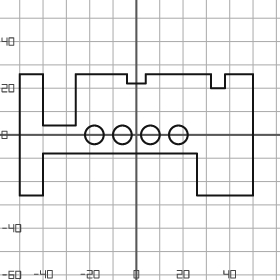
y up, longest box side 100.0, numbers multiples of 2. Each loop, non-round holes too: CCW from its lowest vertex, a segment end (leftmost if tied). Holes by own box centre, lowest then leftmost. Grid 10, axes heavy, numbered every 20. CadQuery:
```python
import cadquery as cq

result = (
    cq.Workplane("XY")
    .moveTo(-50.0, -26.0)
    .lineTo(-40.0, -26.0)
    .lineTo(-40.0, -8.0)
    .lineTo(26.0, -8.0)
    .lineTo(26.0, -26.0)
    .lineTo(50.0, -26.0)
    .lineTo(50.0, 26.0)
    .lineTo(38.0, 26.0)
    .lineTo(38.0, 20.0)
    .lineTo(32.0, 20.0)
    .lineTo(32.0, 26.0)
    .lineTo(4.0, 26.0)
    .lineTo(4.0, 22.0)
    .lineTo(-4.0, 22.0)
    .lineTo(-4.0, 26.0)
    .lineTo(-26.0, 26.0)
    .lineTo(-26.0, 4.0)
    .lineTo(-40.0, 4.0)
    .lineTo(-40.0, 26.0)
    .lineTo(-50.0, 26.0)
    .close()
    .moveTo(-18.0, 0.0)
    .circle(4.0)
    .moveTo(-6.0, 0.0)
    .circle(4.0)
    .moveTo(6.0, 0.0)
    .circle(4.0)
    .moveTo(18.0, 0.0)
    .circle(4.0)
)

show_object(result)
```